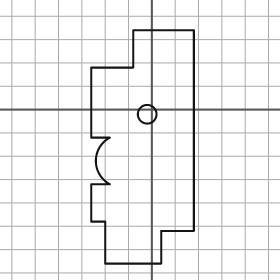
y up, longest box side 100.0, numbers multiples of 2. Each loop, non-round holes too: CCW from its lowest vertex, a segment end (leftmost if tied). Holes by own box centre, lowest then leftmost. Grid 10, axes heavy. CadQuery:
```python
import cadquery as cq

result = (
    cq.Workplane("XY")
    .moveTo(-20.0, -66.0)
    .lineTo(4.0, -66.0)
    .lineTo(4.0, -52.0)
    .lineTo(18.0, -52.0)
    .lineTo(18.0, 34.0)
    .lineTo(-8.0, 34.0)
    .lineTo(-8.0, 18.0)
    .lineTo(-26.0, 18.0)
    .lineTo(-26.0, -12.0)
    .lineTo(-18.0, -12.0)
    .threePointArc((-24.0, -22.0), (-18.0, -32.0))
    .lineTo(-26.0, -32.0)
    .lineTo(-26.0, -48.0)
    .lineTo(-20.0, -48.0)
    .close()
    .moveTo(-2.0, -2.0)
    .circle(4.0)
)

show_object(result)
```